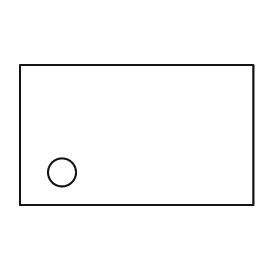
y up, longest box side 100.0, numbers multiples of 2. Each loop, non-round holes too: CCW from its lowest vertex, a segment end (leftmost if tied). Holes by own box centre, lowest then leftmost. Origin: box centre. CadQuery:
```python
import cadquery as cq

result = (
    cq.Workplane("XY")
    .moveTo(-50.0, -30.0)
    .lineTo(50.0, -30.0)
    .lineTo(50.0, 30.0)
    .lineTo(-50.0, 30.0)
    .close()
    .moveTo(-32.0, -16.0)
    .circle(6.0)
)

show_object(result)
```